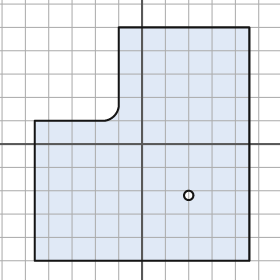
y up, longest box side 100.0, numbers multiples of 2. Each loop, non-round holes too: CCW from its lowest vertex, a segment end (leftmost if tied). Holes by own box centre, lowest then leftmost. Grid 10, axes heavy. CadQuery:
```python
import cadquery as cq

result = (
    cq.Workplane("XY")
    .moveTo(-46.0, -50.0)
    .lineTo(46.0, -50.0)
    .lineTo(46.0, 50.0)
    .lineTo(-10.0, 50.0)
    .lineTo(-10.0, 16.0)
    .threePointArc((-12.0, 12.0), (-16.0, 10.0))
    .lineTo(-46.0, 10.0)
    .close()
    .moveTo(20.0, -22.0)
    .circle(2.0)
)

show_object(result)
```